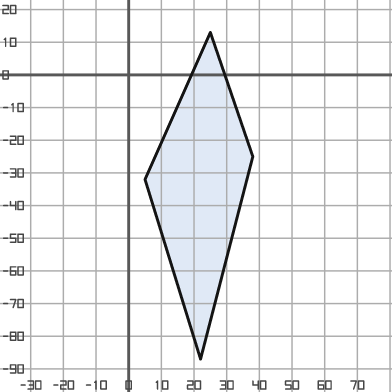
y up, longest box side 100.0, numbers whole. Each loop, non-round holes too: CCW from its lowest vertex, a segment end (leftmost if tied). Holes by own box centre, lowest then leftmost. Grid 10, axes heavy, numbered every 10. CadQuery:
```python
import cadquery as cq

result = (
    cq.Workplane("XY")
    .moveTo(22.0, -87.0)
    .lineTo(38.0, -25.0)
    .lineTo(25.0, 13.0)
    .lineTo(5.0, -32.0)
    .close()
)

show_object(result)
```